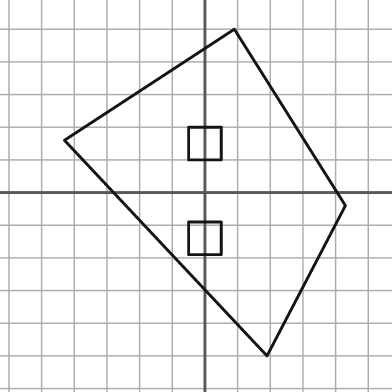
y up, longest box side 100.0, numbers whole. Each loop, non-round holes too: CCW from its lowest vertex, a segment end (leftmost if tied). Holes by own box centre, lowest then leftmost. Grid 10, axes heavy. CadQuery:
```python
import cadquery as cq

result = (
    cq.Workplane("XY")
    .moveTo(19.0, -50.0)
    .lineTo(43.0, -4.0)
    .lineTo(9.0, 50.0)
    .lineTo(-43.0, 16.0)
    .close()
    .moveTo(-5.0, -19.0)
    .lineTo(5.0, -19.0)
    .lineTo(5.0, -9.0)
    .lineTo(-5.0, -9.0)
    .close()
    .moveTo(-5.0, 10.0)
    .lineTo(5.0, 10.0)
    .lineTo(5.0, 20.0)
    .lineTo(-5.0, 20.0)
    .close()
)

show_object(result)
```